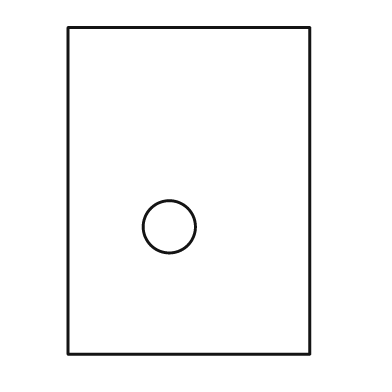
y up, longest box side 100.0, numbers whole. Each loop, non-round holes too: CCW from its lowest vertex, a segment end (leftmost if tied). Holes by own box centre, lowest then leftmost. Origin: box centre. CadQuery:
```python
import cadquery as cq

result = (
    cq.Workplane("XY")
    .moveTo(-37.0, -50.0)
    .lineTo(37.0, -50.0)
    .lineTo(37.0, 50.0)
    .lineTo(-37.0, 50.0)
    .close()
    .moveTo(-6.0, -11.0)
    .circle(8.0)
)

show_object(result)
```